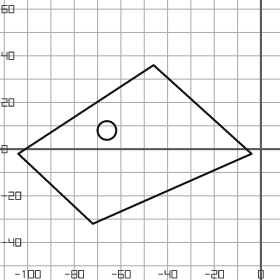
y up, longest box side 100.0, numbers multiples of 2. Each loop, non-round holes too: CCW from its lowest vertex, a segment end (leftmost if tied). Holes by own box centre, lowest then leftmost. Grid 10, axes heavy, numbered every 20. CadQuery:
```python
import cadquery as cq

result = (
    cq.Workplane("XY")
    .moveTo(-72.0, -32.0)
    .lineTo(-4.0, -2.0)
    .lineTo(-46.0, 36.0)
    .lineTo(-104.0, -2.0)
    .close()
    .moveTo(-66.0, 8.0)
    .circle(4.0)
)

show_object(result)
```